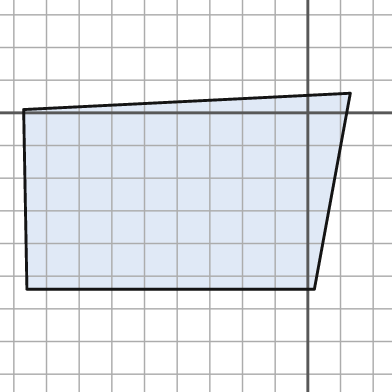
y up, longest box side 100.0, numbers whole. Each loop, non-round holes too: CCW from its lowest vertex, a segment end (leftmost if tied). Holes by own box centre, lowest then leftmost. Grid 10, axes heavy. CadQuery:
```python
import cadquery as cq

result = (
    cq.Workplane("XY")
    .moveTo(-86.0, -54.0)
    .lineTo(2.0, -54.0)
    .lineTo(13.0, 6.0)
    .lineTo(-87.0, 1.0)
    .close()
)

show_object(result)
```